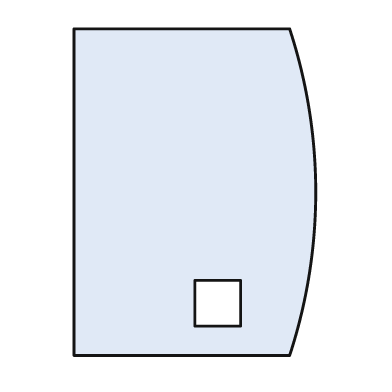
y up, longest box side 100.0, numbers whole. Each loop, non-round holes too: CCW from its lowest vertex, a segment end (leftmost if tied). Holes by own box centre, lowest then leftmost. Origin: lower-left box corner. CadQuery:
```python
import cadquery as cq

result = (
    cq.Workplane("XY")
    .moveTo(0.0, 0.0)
    .lineTo(66.0, 0.0)
    .threePointArc((74.0, 50.0), (66.0, 100.0))
    .lineTo(0.0, 100.0)
    .close()
    .moveTo(37.0, 9.0)
    .lineTo(51.0, 9.0)
    .lineTo(51.0, 23.0)
    .lineTo(37.0, 23.0)
    .close()
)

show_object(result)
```